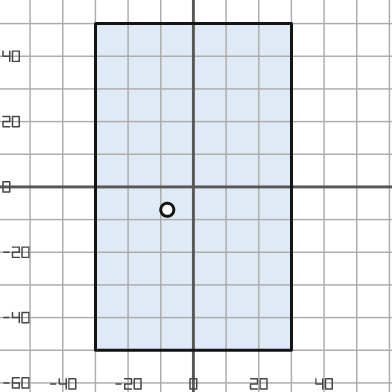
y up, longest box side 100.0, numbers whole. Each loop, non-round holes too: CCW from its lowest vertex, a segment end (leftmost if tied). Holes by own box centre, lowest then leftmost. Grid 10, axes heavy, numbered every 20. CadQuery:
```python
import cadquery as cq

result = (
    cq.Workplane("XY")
    .moveTo(-30.0, -50.0)
    .lineTo(30.0, -50.0)
    .lineTo(30.0, 50.0)
    .lineTo(-30.0, 50.0)
    .close()
    .moveTo(-8.0, -7.0)
    .circle(2.0)
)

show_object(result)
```